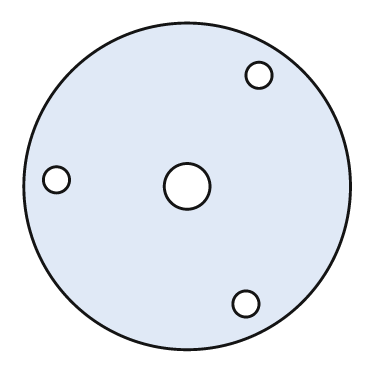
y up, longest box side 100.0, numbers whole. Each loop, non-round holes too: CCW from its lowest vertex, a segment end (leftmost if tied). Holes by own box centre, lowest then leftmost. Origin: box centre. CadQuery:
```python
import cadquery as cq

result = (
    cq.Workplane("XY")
    .moveTo(0.0, 0.0)
    .circle(50.0)
    .moveTo(18.0, -36.0)
    .circle(4.0)
    .moveTo(0.0, 0.0)
    .circle(7.0)
    .moveTo(-40.0, 2.0)
    .circle(4.0)
    .moveTo(22.0, 34.0)
    .circle(4.0)
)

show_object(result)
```